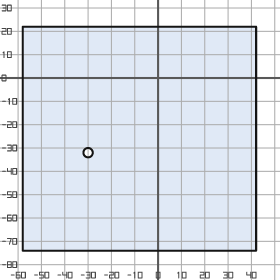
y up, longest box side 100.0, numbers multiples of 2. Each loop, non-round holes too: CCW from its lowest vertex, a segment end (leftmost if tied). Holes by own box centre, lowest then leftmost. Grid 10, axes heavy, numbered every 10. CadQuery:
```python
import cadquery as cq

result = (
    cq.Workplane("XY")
    .moveTo(-58.0, -74.0)
    .lineTo(42.0, -74.0)
    .lineTo(42.0, 22.0)
    .lineTo(-58.0, 22.0)
    .close()
    .moveTo(-30.0, -32.0)
    .circle(2.0)
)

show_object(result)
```